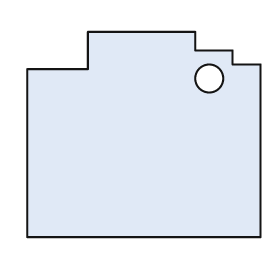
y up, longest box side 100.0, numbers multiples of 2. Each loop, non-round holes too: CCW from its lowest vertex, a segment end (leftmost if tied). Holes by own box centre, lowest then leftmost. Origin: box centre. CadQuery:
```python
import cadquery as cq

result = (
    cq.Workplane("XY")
    .moveTo(-50.0, -44.0)
    .lineTo(50.0, -44.0)
    .lineTo(50.0, 30.0)
    .lineTo(38.0, 30.0)
    .lineTo(38.0, 36.0)
    .lineTo(22.0, 36.0)
    .lineTo(22.0, 44.0)
    .lineTo(-24.0, 44.0)
    .lineTo(-24.0, 28.0)
    .lineTo(-50.0, 28.0)
    .close()
    .moveTo(28.0, 24.0)
    .circle(6.0)
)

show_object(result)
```